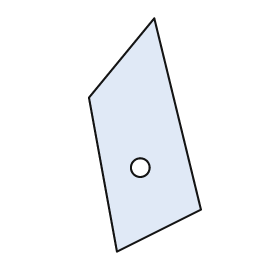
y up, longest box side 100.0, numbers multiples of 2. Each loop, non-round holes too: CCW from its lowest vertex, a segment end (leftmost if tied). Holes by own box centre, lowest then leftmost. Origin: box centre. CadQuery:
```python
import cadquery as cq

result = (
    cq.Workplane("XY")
    .moveTo(-12.0, -50.0)
    .lineTo(24.0, -32.0)
    .lineTo(4.0, 50.0)
    .lineTo(-24.0, 16.0)
    .close()
    .moveTo(-2.0, -14.0)
    .circle(4.0)
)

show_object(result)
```